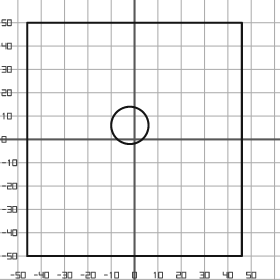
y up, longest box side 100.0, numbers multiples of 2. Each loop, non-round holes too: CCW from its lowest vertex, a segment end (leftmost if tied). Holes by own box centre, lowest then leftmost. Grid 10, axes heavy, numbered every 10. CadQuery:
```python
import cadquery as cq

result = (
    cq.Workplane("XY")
    .moveTo(-46.0, -50.0)
    .lineTo(46.0, -50.0)
    .lineTo(46.0, 50.0)
    .lineTo(-46.0, 50.0)
    .close()
    .moveTo(-2.0, 6.0)
    .circle(8.0)
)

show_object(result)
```